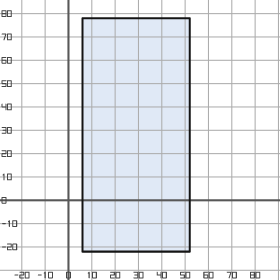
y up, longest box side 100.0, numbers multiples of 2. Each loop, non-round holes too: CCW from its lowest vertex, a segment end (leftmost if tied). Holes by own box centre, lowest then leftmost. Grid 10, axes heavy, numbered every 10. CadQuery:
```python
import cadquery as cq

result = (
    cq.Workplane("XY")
    .moveTo(6.0, -22.0)
    .lineTo(52.0, -22.0)
    .lineTo(52.0, 78.0)
    .lineTo(6.0, 78.0)
    .close()
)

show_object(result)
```